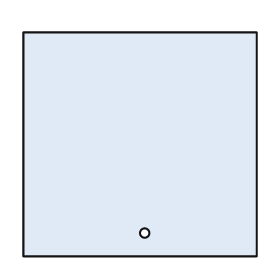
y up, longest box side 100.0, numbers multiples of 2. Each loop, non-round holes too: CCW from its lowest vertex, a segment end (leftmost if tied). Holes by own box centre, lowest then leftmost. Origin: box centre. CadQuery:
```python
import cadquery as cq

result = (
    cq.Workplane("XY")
    .moveTo(-50.0, -48.0)
    .lineTo(50.0, -48.0)
    .lineTo(50.0, 48.0)
    .lineTo(-50.0, 48.0)
    .close()
    .moveTo(2.0, -38.0)
    .circle(2.0)
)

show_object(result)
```